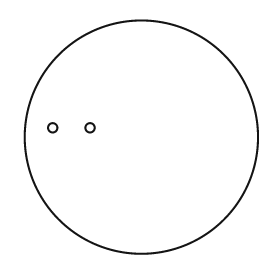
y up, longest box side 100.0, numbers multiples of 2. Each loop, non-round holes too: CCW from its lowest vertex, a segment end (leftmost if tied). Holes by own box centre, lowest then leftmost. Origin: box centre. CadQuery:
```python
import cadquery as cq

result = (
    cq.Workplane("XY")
    .moveTo(0.0, 0.0)
    .circle(50.0)
    .moveTo(-38.0, 4.0)
    .circle(2.0)
    .moveTo(-22.0, 4.0)
    .circle(2.0)
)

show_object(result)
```